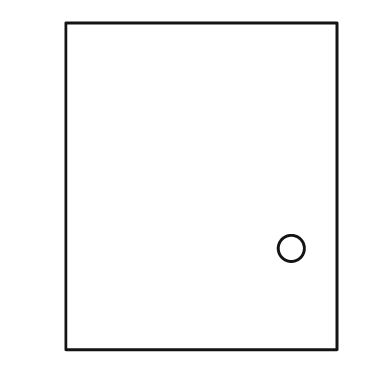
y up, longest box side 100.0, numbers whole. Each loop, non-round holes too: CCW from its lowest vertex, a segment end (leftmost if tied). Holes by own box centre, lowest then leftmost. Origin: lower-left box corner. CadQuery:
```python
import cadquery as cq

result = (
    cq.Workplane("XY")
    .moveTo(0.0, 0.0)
    .lineTo(83.0, 0.0)
    .lineTo(83.0, 100.0)
    .lineTo(0.0, 100.0)
    .close()
    .moveTo(69.0, 31.0)
    .circle(4.0)
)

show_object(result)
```